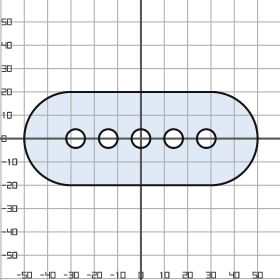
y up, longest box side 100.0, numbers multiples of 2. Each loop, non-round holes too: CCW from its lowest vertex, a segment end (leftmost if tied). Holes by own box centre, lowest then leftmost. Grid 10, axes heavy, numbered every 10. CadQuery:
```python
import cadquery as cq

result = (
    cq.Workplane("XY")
    .moveTo(-30.0, -20.0)
    .lineTo(30.0, -20.0)
    .threePointArc((50.0, 0.0), (30.0, 20.0))
    .lineTo(-30.0, 20.0)
    .threePointArc((-50.0, 0.0), (-30.0, -20.0))
    .close()
    .moveTo(-28.0, 0.0)
    .circle(4.0)
    .moveTo(-14.0, 0.0)
    .circle(4.0)
    .moveTo(0.0, 0.0)
    .circle(4.0)
    .moveTo(14.0, 0.0)
    .circle(4.0)
    .moveTo(28.0, 0.0)
    .circle(4.0)
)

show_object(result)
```